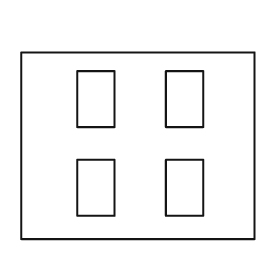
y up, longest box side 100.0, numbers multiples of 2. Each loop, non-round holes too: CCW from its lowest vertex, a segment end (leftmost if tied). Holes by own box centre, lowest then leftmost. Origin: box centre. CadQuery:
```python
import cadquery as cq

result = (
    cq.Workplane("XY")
    .moveTo(-50.0, -40.0)
    .lineTo(50.0, -40.0)
    .lineTo(50.0, 40.0)
    .lineTo(-50.0, 40.0)
    .close()
    .moveTo(-26.0, -30.0)
    .lineTo(-10.0, -30.0)
    .lineTo(-10.0, -6.0)
    .lineTo(-26.0, -6.0)
    .close()
    .moveTo(12.0, -30.0)
    .lineTo(28.0, -30.0)
    .lineTo(28.0, -6.0)
    .lineTo(12.0, -6.0)
    .close()
    .moveTo(-26.0, 8.0)
    .lineTo(-10.0, 8.0)
    .lineTo(-10.0, 32.0)
    .lineTo(-26.0, 32.0)
    .close()
    .moveTo(12.0, 8.0)
    .lineTo(28.0, 8.0)
    .lineTo(28.0, 32.0)
    .lineTo(12.0, 32.0)
    .close()
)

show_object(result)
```